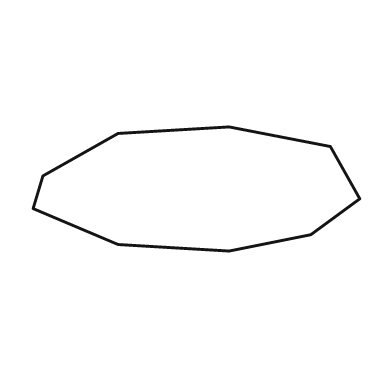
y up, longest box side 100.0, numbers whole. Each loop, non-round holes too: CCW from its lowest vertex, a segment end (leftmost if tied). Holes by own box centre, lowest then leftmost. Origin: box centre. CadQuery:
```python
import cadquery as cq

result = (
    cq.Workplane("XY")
    .moveTo(10.0, -19.0)
    .lineTo(35.0, -14.0)
    .lineTo(50.0, -3.0)
    .lineTo(41.0, 13.0)
    .lineTo(10.0, 19.0)
    .lineTo(-24.0, 17.0)
    .lineTo(-47.0, 4.0)
    .lineTo(-50.0, -6.0)
    .lineTo(-24.0, -17.0)
    .close()
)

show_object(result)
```